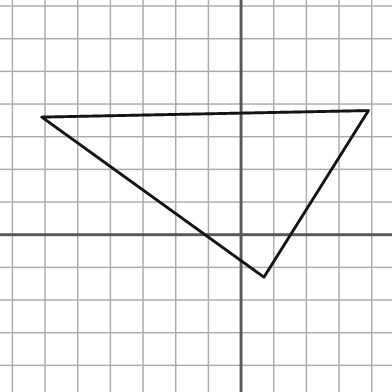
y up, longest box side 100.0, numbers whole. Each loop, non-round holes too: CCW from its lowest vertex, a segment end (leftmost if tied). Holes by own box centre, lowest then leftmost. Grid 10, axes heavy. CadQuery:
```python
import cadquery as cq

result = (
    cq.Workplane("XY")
    .moveTo(7.0, -13.0)
    .lineTo(39.0, 38.0)
    .lineTo(-61.0, 36.0)
    .close()
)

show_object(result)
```